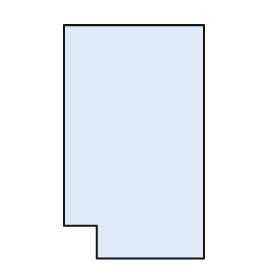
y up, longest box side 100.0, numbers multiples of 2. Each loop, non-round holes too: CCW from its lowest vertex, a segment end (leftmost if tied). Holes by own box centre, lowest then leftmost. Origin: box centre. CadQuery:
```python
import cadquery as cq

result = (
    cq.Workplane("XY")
    .moveTo(-16.0, -50.0)
    .lineTo(30.0, -50.0)
    .lineTo(30.0, 50.0)
    .lineTo(-30.0, 50.0)
    .lineTo(-30.0, -36.0)
    .lineTo(-16.0, -36.0)
    .close()
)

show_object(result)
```